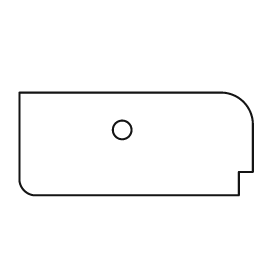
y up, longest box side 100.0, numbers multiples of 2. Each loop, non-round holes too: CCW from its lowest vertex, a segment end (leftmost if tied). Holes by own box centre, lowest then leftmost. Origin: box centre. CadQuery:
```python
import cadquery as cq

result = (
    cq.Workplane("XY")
    .moveTo(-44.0, -22.0)
    .lineTo(44.0, -22.0)
    .lineTo(44.0, -12.0)
    .lineTo(50.0, -12.0)
    .lineTo(50.0, 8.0)
    .threePointArc((46.0, 18.0), (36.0, 22.0))
    .lineTo(-50.0, 22.0)
    .lineTo(-50.0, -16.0)
    .threePointArc((-48.0, -20.0), (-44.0, -22.0))
    .close()
    .moveTo(-6.0, 6.0)
    .circle(4.0)
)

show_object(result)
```